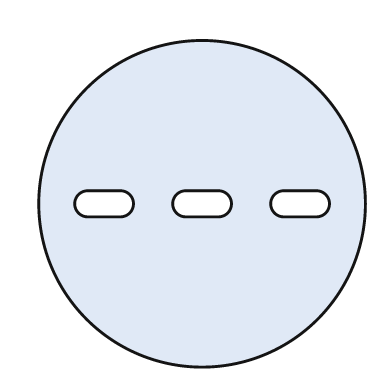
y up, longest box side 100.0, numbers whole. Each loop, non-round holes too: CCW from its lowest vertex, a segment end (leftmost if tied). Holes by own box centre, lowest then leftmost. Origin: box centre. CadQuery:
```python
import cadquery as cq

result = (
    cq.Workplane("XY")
    .moveTo(0.0, 0.0)
    .circle(50.0)
    .moveTo(-35.0, -4.0)
    .lineTo(-25.0, -4.0)
    .threePointArc((-21.0, 0.0), (-25.0, 4.0))
    .lineTo(-35.0, 4.0)
    .threePointArc((-39.0, 0.0), (-35.0, -4.0))
    .close()
    .moveTo(-5.0, -4.0)
    .lineTo(5.0, -4.0)
    .threePointArc((9.0, 0.0), (5.0, 4.0))
    .lineTo(-5.0, 4.0)
    .threePointArc((-9.0, 0.0), (-5.0, -4.0))
    .close()
    .moveTo(25.0, -4.0)
    .lineTo(35.0, -4.0)
    .threePointArc((39.0, 0.0), (35.0, 4.0))
    .lineTo(25.0, 4.0)
    .threePointArc((21.0, 0.0), (25.0, -4.0))
    .close()
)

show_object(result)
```